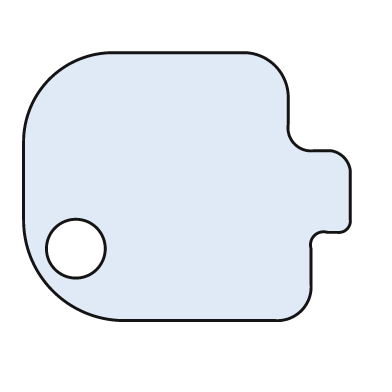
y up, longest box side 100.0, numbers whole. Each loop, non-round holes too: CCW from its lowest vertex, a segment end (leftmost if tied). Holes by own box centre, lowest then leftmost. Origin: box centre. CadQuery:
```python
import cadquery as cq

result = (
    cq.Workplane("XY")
    .moveTo(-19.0, -41.0)
    .lineTo(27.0, -41.0)
    .threePointArc((35.0, -38.0), (38.0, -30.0))
    .lineTo(38.0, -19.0)
    .threePointArc((39.0, -15.0), (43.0, -14.0))
    .lineTo(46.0, -14.0)
    .threePointArc((49.0, -13.0), (50.0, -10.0))
    .lineTo(50.0, 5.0)
    .threePointArc((48.0, 9.0), (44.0, 11.0))
    .lineTo(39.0, 11.0)
    .threePointArc((33.0, 13.0), (31.0, 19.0))
    .lineTo(31.0, 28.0)
    .threePointArc((27.0, 37.0), (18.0, 41.0))
    .lineTo(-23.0, 41.0)
    .threePointArc((-42.0, 33.0), (-50.0, 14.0))
    .lineTo(-50.0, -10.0)
    .threePointArc((-41.0, -32.0), (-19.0, -41.0))
    .close()
    .moveTo(-34.0, -19.0)
    .circle(9.0)
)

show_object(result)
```